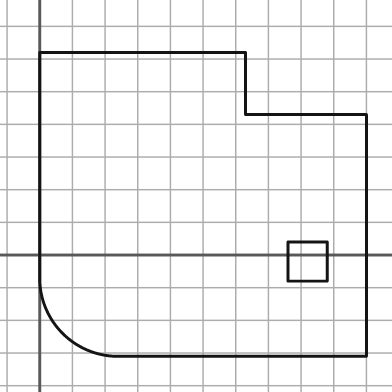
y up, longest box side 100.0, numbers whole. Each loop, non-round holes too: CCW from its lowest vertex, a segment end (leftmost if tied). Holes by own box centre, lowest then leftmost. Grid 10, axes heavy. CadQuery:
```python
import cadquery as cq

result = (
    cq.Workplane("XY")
    .moveTo(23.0, -31.0)
    .lineTo(100.0, -31.0)
    .lineTo(100.0, 43.0)
    .lineTo(63.0, 43.0)
    .lineTo(63.0, 62.0)
    .lineTo(0.0, 62.0)
    .lineTo(0.0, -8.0)
    .threePointArc((7.0, -24.0), (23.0, -31.0))
    .close()
    .moveTo(76.0, -8.0)
    .lineTo(88.0, -8.0)
    .lineTo(88.0, 4.0)
    .lineTo(76.0, 4.0)
    .close()
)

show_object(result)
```